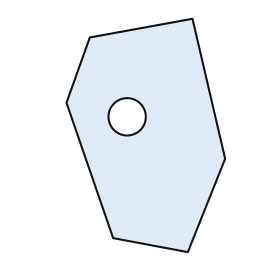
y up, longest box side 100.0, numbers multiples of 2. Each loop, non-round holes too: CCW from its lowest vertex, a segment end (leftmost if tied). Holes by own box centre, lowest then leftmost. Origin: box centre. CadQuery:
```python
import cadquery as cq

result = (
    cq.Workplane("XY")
    .moveTo(18.0, -50.0)
    .lineTo(34.0, -10.0)
    .lineTo(20.0, 50.0)
    .lineTo(-24.0, 42.0)
    .lineTo(-34.0, 14.0)
    .lineTo(-14.0, -44.0)
    .close()
    .moveTo(-8.0, 8.0)
    .circle(8.0)
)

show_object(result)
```